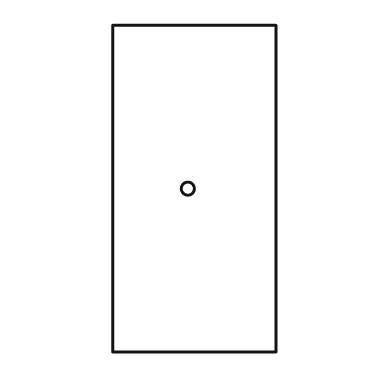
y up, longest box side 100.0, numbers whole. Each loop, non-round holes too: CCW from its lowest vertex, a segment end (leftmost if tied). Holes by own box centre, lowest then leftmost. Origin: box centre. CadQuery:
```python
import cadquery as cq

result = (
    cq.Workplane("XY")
    .moveTo(-25.0, -50.0)
    .lineTo(25.0, -50.0)
    .lineTo(25.0, 50.0)
    .lineTo(-25.0, 50.0)
    .close()
    .moveTo(-2.0, 0.0)
    .circle(2.0)
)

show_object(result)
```